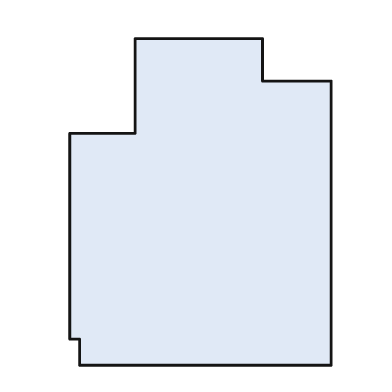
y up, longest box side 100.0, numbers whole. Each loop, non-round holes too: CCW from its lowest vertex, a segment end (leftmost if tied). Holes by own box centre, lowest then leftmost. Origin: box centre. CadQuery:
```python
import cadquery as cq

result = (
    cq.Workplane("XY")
    .moveTo(-37.0, -50.0)
    .lineTo(40.0, -50.0)
    .lineTo(40.0, 37.0)
    .lineTo(19.0, 37.0)
    .lineTo(19.0, 50.0)
    .lineTo(-20.0, 50.0)
    .lineTo(-20.0, 21.0)
    .lineTo(-40.0, 21.0)
    .lineTo(-40.0, -42.0)
    .lineTo(-37.0, -42.0)
    .close()
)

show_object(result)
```